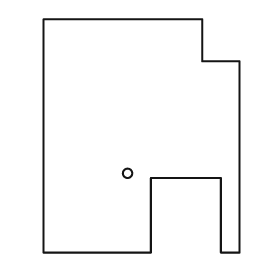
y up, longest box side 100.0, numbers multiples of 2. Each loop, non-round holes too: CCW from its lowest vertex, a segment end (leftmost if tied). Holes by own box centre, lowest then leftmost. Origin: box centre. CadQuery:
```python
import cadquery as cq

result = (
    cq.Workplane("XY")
    .moveTo(-42.0, -50.0)
    .lineTo(4.0, -50.0)
    .lineTo(4.0, -18.0)
    .lineTo(34.0, -18.0)
    .lineTo(34.0, -50.0)
    .lineTo(42.0, -50.0)
    .lineTo(42.0, 32.0)
    .lineTo(26.0, 32.0)
    .lineTo(26.0, 50.0)
    .lineTo(-42.0, 50.0)
    .close()
    .moveTo(-6.0, -16.0)
    .circle(2.0)
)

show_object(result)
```